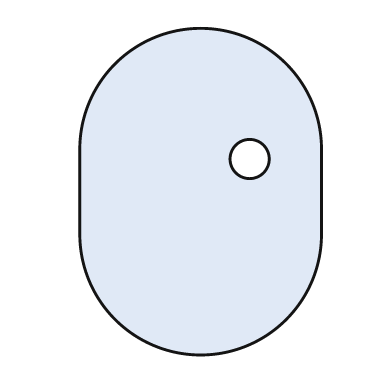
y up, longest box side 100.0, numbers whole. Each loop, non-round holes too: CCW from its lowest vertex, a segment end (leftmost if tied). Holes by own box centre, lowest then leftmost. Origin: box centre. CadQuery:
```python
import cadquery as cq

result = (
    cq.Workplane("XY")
    .moveTo(-37.0, -13.0)
    .threePointArc((0.0, -50.0), (37.0, -13.0))
    .lineTo(37.0, 13.0)
    .threePointArc((0.0, 50.0), (-37.0, 13.0))
    .close()
    .moveTo(15.0, 10.0)
    .circle(6.0)
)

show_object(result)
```